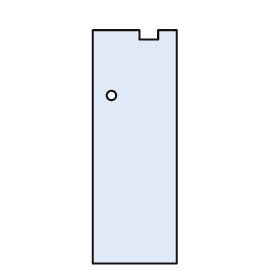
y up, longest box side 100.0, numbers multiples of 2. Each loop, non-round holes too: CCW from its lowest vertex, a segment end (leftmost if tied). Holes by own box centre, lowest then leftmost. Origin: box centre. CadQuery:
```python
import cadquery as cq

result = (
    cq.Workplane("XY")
    .moveTo(-18.0, -50.0)
    .lineTo(18.0, -50.0)
    .lineTo(18.0, 50.0)
    .lineTo(10.0, 50.0)
    .lineTo(10.0, 46.0)
    .lineTo(2.0, 46.0)
    .lineTo(2.0, 50.0)
    .lineTo(-18.0, 50.0)
    .close()
    .moveTo(-10.0, 22.0)
    .circle(2.0)
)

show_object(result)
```